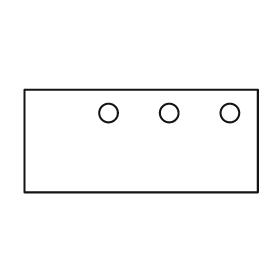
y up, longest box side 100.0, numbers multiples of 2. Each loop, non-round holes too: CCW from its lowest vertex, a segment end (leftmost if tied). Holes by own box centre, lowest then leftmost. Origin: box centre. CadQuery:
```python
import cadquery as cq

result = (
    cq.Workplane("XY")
    .moveTo(-50.0, -22.0)
    .lineTo(50.0, -22.0)
    .lineTo(50.0, 22.0)
    .lineTo(-50.0, 22.0)
    .close()
    .moveTo(-14.0, 12.0)
    .circle(4.0)
    .moveTo(12.0, 12.0)
    .circle(4.0)
    .moveTo(38.0, 12.0)
    .circle(4.0)
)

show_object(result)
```